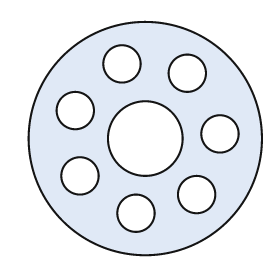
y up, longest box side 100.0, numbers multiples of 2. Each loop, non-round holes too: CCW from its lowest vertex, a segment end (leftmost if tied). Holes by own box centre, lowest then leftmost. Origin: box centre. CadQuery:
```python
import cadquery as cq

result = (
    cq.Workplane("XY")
    .moveTo(0.0, 0.0)
    .circle(50.0)
    .moveTo(-4.0, -32.0)
    .circle(8.0)
    .moveTo(22.0, -24.0)
    .circle(8.0)
    .moveTo(-28.0, -16.0)
    .circle(8.0)
    .moveTo(0.0, 0.0)
    .circle(16.0)
    .moveTo(32.0, 2.0)
    .circle(8.0)
    .moveTo(-30.0, 12.0)
    .circle(8.0)
    .moveTo(18.0, 28.0)
    .circle(8.0)
    .moveTo(-10.0, 32.0)
    .circle(8.0)
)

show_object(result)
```